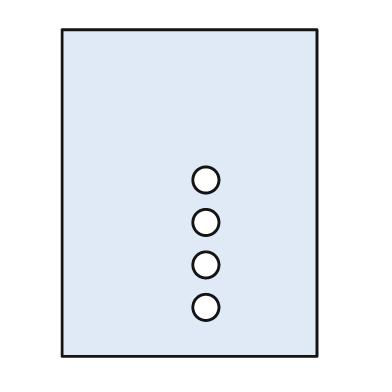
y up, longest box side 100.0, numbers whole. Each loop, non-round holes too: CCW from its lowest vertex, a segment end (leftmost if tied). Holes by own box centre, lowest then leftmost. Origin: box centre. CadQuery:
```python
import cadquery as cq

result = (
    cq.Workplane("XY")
    .moveTo(-39.0, -50.0)
    .lineTo(39.0, -50.0)
    .lineTo(39.0, 50.0)
    .lineTo(-39.0, 50.0)
    .close()
    .moveTo(5.0, -35.0)
    .circle(4.0)
    .moveTo(5.0, -22.0)
    .circle(4.0)
    .moveTo(5.0, -9.0)
    .circle(4.0)
    .moveTo(5.0, 4.0)
    .circle(4.0)
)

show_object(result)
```